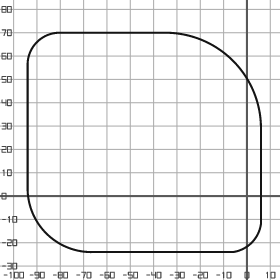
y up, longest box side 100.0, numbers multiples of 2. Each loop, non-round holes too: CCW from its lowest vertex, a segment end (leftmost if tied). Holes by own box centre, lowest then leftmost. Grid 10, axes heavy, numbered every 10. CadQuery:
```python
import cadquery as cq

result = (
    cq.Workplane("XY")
    .moveTo(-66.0, -24.0)
    .lineTo(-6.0, -24.0)
    .threePointArc((2.0, -20.0), (6.0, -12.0))
    .lineTo(6.0, 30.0)
    .threePointArc((-6.0, 58.0), (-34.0, 70.0))
    .lineTo(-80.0, 70.0)
    .threePointArc((-90.0, 66.0), (-94.0, 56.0))
    .lineTo(-94.0, 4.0)
    .threePointArc((-86.0, -16.0), (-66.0, -24.0))
    .close()
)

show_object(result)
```